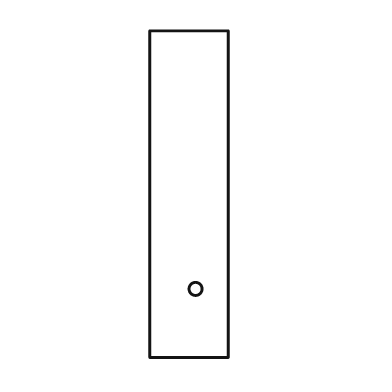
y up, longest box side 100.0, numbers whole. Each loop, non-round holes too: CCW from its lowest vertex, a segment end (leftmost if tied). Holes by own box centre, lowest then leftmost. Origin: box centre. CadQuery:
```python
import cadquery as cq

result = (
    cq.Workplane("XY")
    .moveTo(-12.0, -50.0)
    .lineTo(12.0, -50.0)
    .lineTo(12.0, 50.0)
    .lineTo(-12.0, 50.0)
    .close()
    .moveTo(2.0, -29.0)
    .circle(2.0)
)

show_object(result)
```